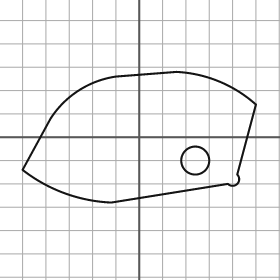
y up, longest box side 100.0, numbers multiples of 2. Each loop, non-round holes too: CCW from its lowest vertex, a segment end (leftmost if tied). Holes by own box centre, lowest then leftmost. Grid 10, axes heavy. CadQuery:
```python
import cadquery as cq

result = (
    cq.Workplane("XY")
    .moveTo(-12.0, -28.0)
    .lineTo(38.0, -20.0)
    .threePointArc((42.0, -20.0), (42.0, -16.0))
    .lineTo(50.0, 14.0)
    .threePointArc((34.0, 24.0), (16.0, 28.0))
    .lineTo(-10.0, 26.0)
    .threePointArc((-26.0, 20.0), (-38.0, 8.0))
    .lineTo(-50.0, -14.0)
    .threePointArc((-32.0, -24.0), (-12.0, -28.0))
    .close()
    .moveTo(24.0, -10.0)
    .circle(6.0)
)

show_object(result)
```